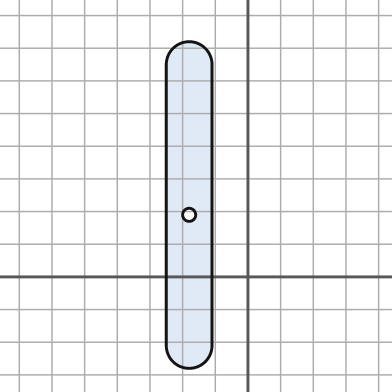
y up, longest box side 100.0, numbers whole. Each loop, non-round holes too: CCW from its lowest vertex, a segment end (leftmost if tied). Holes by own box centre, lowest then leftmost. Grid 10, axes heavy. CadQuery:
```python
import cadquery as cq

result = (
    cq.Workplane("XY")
    .moveTo(-25.0, -21.0)
    .threePointArc((-18.0, -28.0), (-11.0, -21.0))
    .lineTo(-11.0, 65.0)
    .threePointArc((-18.0, 72.0), (-25.0, 65.0))
    .close()
    .moveTo(-18.0, 19.0)
    .circle(2.0)
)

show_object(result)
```